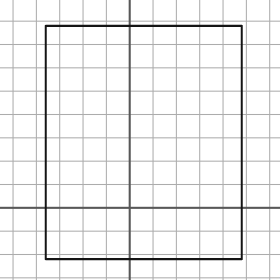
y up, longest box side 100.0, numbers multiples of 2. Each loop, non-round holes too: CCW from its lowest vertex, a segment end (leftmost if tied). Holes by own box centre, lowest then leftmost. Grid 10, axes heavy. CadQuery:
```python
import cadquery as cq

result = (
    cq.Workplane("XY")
    .moveTo(-36.0, -22.0)
    .lineTo(48.0, -22.0)
    .lineTo(48.0, 78.0)
    .lineTo(-36.0, 78.0)
    .close()
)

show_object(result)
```